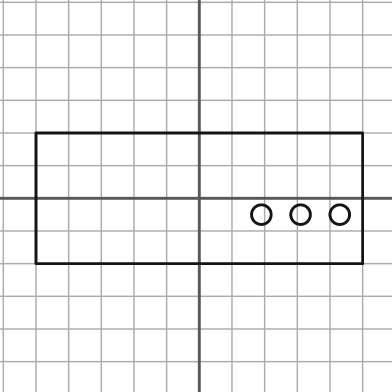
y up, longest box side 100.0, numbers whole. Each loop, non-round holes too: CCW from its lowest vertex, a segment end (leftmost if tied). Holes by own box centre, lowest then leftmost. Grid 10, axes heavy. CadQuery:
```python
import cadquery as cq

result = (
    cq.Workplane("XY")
    .moveTo(-50.0, -20.0)
    .lineTo(50.0, -20.0)
    .lineTo(50.0, 20.0)
    .lineTo(-50.0, 20.0)
    .close()
    .moveTo(19.0, -5.0)
    .circle(3.0)
    .moveTo(31.0, -5.0)
    .circle(3.0)
    .moveTo(43.0, -5.0)
    .circle(3.0)
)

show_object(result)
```